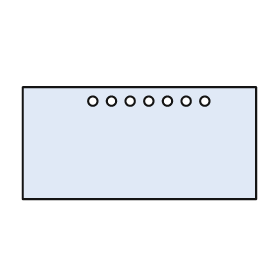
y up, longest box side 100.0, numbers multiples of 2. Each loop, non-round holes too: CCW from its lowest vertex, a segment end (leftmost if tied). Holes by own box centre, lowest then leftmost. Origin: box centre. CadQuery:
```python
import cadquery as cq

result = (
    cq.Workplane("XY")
    .moveTo(-50.0, -24.0)
    .lineTo(50.0, -24.0)
    .lineTo(50.0, 24.0)
    .lineTo(-50.0, 24.0)
    .close()
    .moveTo(-20.0, 18.0)
    .circle(2.0)
    .moveTo(-12.0, 18.0)
    .circle(2.0)
    .moveTo(-4.0, 18.0)
    .circle(2.0)
    .moveTo(4.0, 18.0)
    .circle(2.0)
    .moveTo(12.0, 18.0)
    .circle(2.0)
    .moveTo(20.0, 18.0)
    .circle(2.0)
    .moveTo(28.0, 18.0)
    .circle(2.0)
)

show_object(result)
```